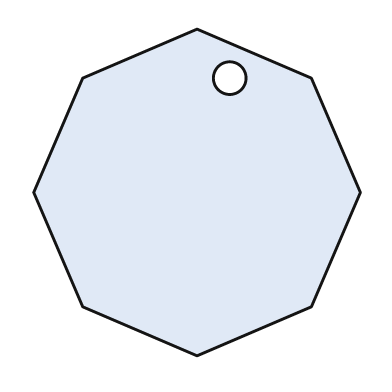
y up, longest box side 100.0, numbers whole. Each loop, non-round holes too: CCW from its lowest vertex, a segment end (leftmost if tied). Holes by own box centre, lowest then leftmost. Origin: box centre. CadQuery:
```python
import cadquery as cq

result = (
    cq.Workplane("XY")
    .moveTo(0.0, -50.0)
    .lineTo(35.0, -35.0)
    .lineTo(50.0, 0.0)
    .lineTo(35.0, 35.0)
    .lineTo(0.0, 50.0)
    .lineTo(-35.0, 35.0)
    .lineTo(-50.0, 0.0)
    .lineTo(-35.0, -35.0)
    .close()
    .moveTo(10.0, 35.0)
    .circle(5.0)
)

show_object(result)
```